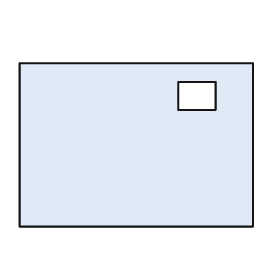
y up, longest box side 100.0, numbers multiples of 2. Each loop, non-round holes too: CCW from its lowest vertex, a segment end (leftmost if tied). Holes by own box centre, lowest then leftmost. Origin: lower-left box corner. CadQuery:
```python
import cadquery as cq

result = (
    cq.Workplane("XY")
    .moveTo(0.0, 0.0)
    .lineTo(100.0, 0.0)
    .lineTo(100.0, 70.0)
    .lineTo(0.0, 70.0)
    .close()
    .moveTo(68.0, 50.0)
    .lineTo(84.0, 50.0)
    .lineTo(84.0, 62.0)
    .lineTo(68.0, 62.0)
    .close()
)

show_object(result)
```